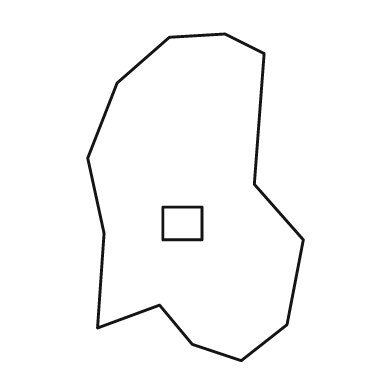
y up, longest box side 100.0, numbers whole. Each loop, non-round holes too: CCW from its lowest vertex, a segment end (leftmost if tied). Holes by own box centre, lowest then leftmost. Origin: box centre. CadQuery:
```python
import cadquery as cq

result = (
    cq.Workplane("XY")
    .moveTo(14.0, -50.0)
    .lineTo(28.0, -39.0)
    .lineTo(33.0, -13.0)
    .lineTo(18.0, 4.0)
    .lineTo(21.0, 44.0)
    .lineTo(9.0, 50.0)
    .lineTo(-8.0, 49.0)
    .lineTo(-24.0, 35.0)
    .lineTo(-33.0, 12.0)
    .lineTo(-28.0, -11.0)
    .lineTo(-30.0, -40.0)
    .lineTo(-11.0, -33.0)
    .lineTo(-1.0, -45.0)
    .close()
    .moveTo(-10.0, -13.0)
    .lineTo(2.0, -13.0)
    .lineTo(2.0, -3.0)
    .lineTo(-10.0, -3.0)
    .close()
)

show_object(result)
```